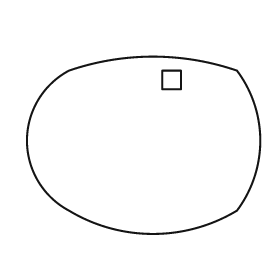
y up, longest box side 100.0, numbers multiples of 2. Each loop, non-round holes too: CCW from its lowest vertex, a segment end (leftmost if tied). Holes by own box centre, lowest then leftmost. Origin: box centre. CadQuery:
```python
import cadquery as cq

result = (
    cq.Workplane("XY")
    .moveTo(-32.0, -28.0)
    .threePointArc((4.0, -38.0), (40.0, -28.0))
    .threePointArc((50.0, 2.0), (40.0, 32.0))
    .threePointArc((4.0, 38.0), (-32.0, 32.0))
    .threePointArc((-50.0, 2.0), (-32.0, -28.0))
    .close()
    .moveTo(8.0, 24.0)
    .lineTo(16.0, 24.0)
    .lineTo(16.0, 32.0)
    .lineTo(8.0, 32.0)
    .close()
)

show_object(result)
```